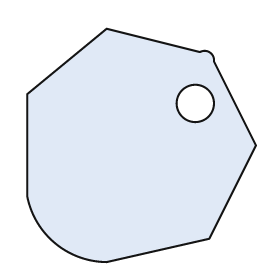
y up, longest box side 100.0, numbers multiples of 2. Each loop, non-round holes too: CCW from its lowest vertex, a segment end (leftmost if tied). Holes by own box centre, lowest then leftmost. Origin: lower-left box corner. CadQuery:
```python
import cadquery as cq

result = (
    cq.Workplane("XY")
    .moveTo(34.0, 0.0)
    .lineTo(78.0, 10.0)
    .lineTo(98.0, 50.0)
    .lineTo(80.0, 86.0)
    .threePointArc((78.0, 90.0), (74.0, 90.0))
    .lineTo(34.0, 100.0)
    .lineTo(0.0, 72.0)
    .lineTo(0.0, 28.0)
    .threePointArc((12.0, 8.0), (34.0, 0.0))
    .close()
    .moveTo(72.0, 68.0)
    .circle(8.0)
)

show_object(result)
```